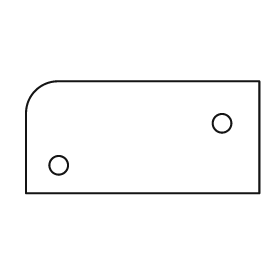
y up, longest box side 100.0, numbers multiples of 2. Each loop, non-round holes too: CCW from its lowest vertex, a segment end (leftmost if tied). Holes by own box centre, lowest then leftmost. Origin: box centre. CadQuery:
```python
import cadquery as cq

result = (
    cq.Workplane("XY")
    .moveTo(-50.0, -24.0)
    .lineTo(50.0, -24.0)
    .lineTo(50.0, 24.0)
    .lineTo(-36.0, 24.0)
    .threePointArc((-46.0, 20.0), (-50.0, 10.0))
    .close()
    .moveTo(-36.0, -12.0)
    .circle(4.0)
    .moveTo(34.0, 6.0)
    .circle(4.0)
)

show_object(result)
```